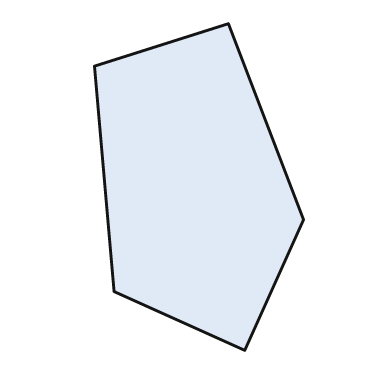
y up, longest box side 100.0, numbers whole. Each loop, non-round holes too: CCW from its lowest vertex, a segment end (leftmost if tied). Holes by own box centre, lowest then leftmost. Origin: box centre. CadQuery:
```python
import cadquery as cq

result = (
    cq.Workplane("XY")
    .moveTo(14.0, -50.0)
    .lineTo(32.0, -10.0)
    .lineTo(9.0, 50.0)
    .lineTo(-32.0, 37.0)
    .lineTo(-26.0, -32.0)
    .close()
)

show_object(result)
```